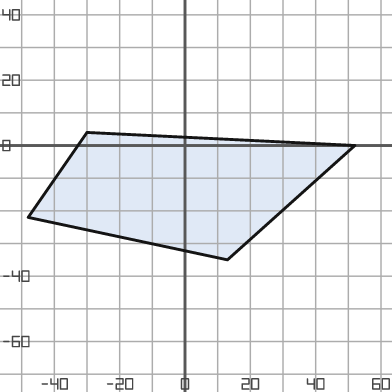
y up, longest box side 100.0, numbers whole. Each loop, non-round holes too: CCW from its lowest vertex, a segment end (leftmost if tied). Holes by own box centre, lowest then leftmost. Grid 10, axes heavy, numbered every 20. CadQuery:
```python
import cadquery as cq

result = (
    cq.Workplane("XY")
    .moveTo(13.0, -35.0)
    .lineTo(52.0, 0.0)
    .lineTo(-30.0, 4.0)
    .lineTo(-48.0, -22.0)
    .close()
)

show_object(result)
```